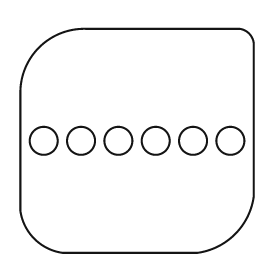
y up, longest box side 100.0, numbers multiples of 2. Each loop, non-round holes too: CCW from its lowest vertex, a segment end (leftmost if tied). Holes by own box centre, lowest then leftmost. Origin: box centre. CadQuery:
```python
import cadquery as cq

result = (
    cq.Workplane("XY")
    .moveTo(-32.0, -48.0)
    .lineTo(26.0, -48.0)
    .threePointArc((42.0, -40.0), (50.0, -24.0))
    .lineTo(50.0, 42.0)
    .threePointArc((48.0, 46.0), (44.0, 48.0))
    .lineTo(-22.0, 48.0)
    .threePointArc((-42.0, 40.0), (-50.0, 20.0))
    .lineTo(-50.0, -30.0)
    .threePointArc((-44.0, -42.0), (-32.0, -48.0))
    .close()
    .moveTo(-40.0, 0.0)
    .circle(6.0)
    .moveTo(-24.0, 0.0)
    .circle(6.0)
    .moveTo(-8.0, 0.0)
    .circle(6.0)
    .moveTo(8.0, 0.0)
    .circle(6.0)
    .moveTo(24.0, 0.0)
    .circle(6.0)
    .moveTo(40.0, 0.0)
    .circle(6.0)
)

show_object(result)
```